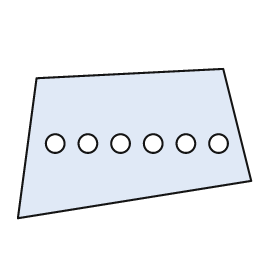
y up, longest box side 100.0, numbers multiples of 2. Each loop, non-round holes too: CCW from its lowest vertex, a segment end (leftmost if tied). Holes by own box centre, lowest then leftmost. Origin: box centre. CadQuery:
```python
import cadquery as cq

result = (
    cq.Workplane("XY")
    .moveTo(-50.0, -32.0)
    .lineTo(50.0, -16.0)
    .lineTo(38.0, 32.0)
    .lineTo(-42.0, 28.0)
    .close()
    .moveTo(-34.0, 0.0)
    .circle(4.0)
    .moveTo(-20.0, 0.0)
    .circle(4.0)
    .moveTo(-6.0, 0.0)
    .circle(4.0)
    .moveTo(8.0, 0.0)
    .circle(4.0)
    .moveTo(22.0, 0.0)
    .circle(4.0)
    .moveTo(36.0, 0.0)
    .circle(4.0)
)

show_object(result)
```